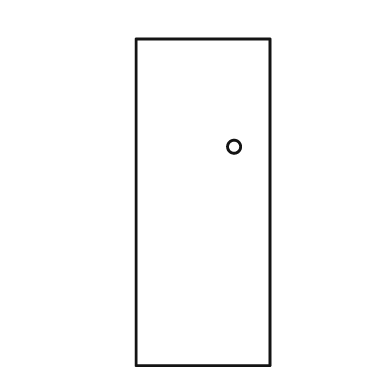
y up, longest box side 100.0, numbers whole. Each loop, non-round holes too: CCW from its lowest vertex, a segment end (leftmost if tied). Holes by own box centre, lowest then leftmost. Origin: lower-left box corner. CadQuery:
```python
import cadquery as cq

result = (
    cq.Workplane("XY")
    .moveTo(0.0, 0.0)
    .lineTo(41.0, 0.0)
    .lineTo(41.0, 100.0)
    .lineTo(0.0, 100.0)
    .close()
    .moveTo(30.0, 67.0)
    .circle(2.0)
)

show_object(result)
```